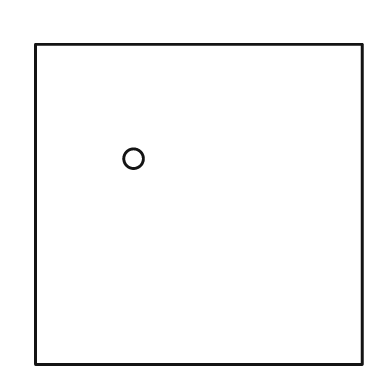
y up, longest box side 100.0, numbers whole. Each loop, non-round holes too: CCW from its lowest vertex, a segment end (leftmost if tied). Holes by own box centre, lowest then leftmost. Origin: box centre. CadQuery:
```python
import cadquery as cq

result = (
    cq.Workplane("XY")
    .moveTo(-50.0, -49.0)
    .lineTo(50.0, -49.0)
    .lineTo(50.0, 49.0)
    .lineTo(-50.0, 49.0)
    .close()
    .moveTo(-20.0, 14.0)
    .circle(3.0)
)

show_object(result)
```